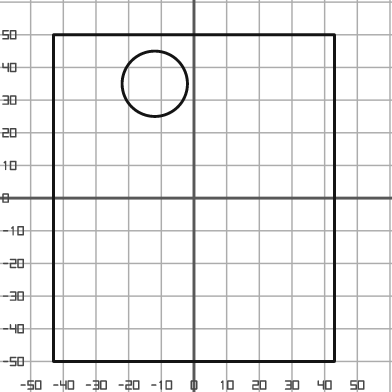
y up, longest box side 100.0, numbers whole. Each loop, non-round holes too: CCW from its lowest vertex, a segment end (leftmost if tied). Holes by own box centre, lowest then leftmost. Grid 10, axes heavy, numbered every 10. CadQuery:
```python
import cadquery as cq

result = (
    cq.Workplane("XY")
    .moveTo(-43.0, -50.0)
    .lineTo(43.0, -50.0)
    .lineTo(43.0, 50.0)
    .lineTo(-43.0, 50.0)
    .close()
    .moveTo(-12.0, 35.0)
    .circle(10.0)
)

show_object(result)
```